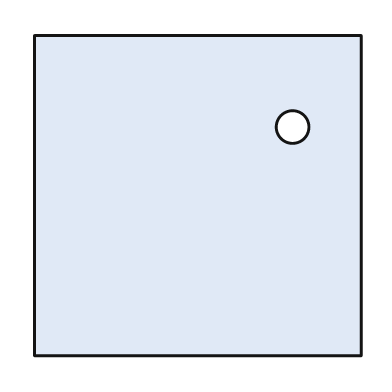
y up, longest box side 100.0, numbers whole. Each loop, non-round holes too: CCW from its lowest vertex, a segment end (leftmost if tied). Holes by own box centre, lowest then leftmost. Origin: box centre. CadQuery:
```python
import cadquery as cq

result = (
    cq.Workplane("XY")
    .moveTo(-50.0, -49.0)
    .lineTo(50.0, -49.0)
    .lineTo(50.0, 49.0)
    .lineTo(-50.0, 49.0)
    .close()
    .moveTo(29.0, 21.0)
    .circle(5.0)
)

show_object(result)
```